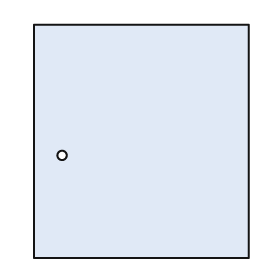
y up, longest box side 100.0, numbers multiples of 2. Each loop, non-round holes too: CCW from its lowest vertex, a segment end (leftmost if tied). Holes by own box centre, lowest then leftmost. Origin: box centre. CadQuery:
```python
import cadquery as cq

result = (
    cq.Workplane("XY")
    .moveTo(-46.0, -50.0)
    .lineTo(46.0, -50.0)
    .lineTo(46.0, 50.0)
    .lineTo(-46.0, 50.0)
    .close()
    .moveTo(-34.0, -6.0)
    .circle(2.0)
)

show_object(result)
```